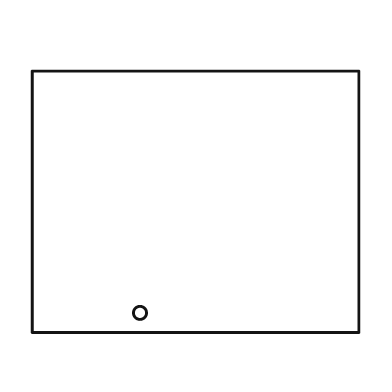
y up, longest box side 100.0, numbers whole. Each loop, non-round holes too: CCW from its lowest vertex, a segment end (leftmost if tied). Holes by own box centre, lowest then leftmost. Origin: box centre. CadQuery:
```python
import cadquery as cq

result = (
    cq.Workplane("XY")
    .moveTo(-50.0, -40.0)
    .lineTo(50.0, -40.0)
    .lineTo(50.0, 40.0)
    .lineTo(-50.0, 40.0)
    .close()
    .moveTo(-17.0, -34.0)
    .circle(2.0)
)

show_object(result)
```